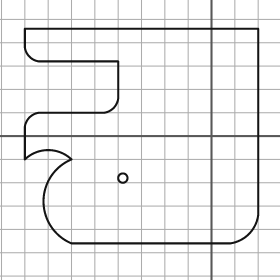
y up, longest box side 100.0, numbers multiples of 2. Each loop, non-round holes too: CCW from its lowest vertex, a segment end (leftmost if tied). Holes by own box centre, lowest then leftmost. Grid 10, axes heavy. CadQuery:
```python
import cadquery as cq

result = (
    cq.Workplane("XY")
    .moveTo(-60.0, -46.0)
    .lineTo(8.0, -46.0)
    .threePointArc((16.0, -42.0), (20.0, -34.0))
    .lineTo(20.0, 46.0)
    .lineTo(-80.0, 46.0)
    .lineTo(-80.0, 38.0)
    .threePointArc((-78.0, 34.0), (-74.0, 32.0))
    .lineTo(-40.0, 32.0)
    .lineTo(-40.0, 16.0)
    .threePointArc((-42.0, 12.0), (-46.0, 10.0))
    .lineTo(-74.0, 10.0)
    .threePointArc((-78.0, 8.0), (-80.0, 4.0))
    .lineTo(-80.0, -10.0)
    .threePointArc((-70.0, -6.0), (-60.0, -10.0))
    .threePointArc((-72.0, -28.0), (-60.0, -46.0))
    .close()
    .moveTo(-38.0, -18.0)
    .circle(2.0)
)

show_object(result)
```